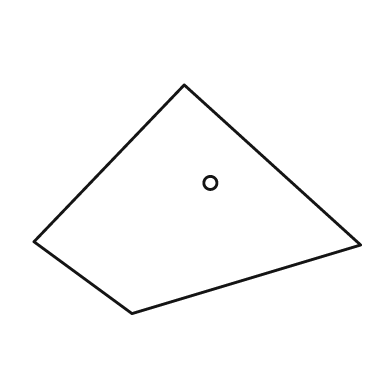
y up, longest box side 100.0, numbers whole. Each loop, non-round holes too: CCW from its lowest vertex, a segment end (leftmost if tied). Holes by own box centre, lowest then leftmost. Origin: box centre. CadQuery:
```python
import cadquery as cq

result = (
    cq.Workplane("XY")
    .moveTo(-20.0, -35.0)
    .lineTo(50.0, -14.0)
    .lineTo(-4.0, 35.0)
    .lineTo(-50.0, -13.0)
    .close()
    .moveTo(4.0, 5.0)
    .circle(2.0)
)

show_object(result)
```